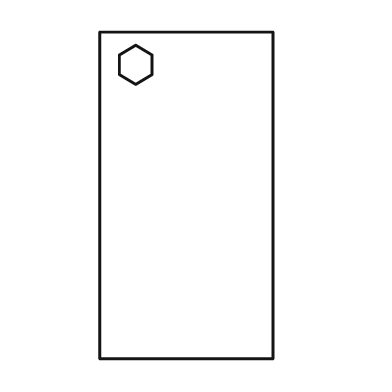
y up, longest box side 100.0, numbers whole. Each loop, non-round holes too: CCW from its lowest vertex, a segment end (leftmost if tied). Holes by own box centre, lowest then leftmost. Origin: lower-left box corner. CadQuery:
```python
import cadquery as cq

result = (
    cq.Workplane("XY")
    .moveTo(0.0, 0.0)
    .lineTo(53.0, 0.0)
    .lineTo(53.0, 100.0)
    .lineTo(0.0, 100.0)
    .close()
    .moveTo(11.0, 84.0)
    .lineTo(16.0, 87.0)
    .lineTo(16.0, 93.0)
    .lineTo(11.0, 96.0)
    .lineTo(6.0, 93.0)
    .lineTo(6.0, 87.0)
    .close()
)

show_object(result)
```